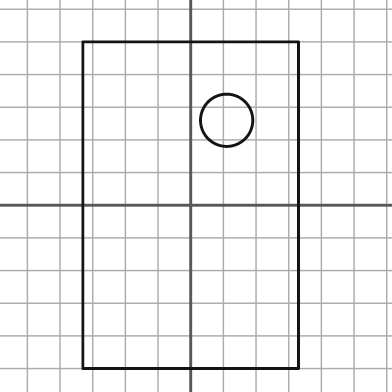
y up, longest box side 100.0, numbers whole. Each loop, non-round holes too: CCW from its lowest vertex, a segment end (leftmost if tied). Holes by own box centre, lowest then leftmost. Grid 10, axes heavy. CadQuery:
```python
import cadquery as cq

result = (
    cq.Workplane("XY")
    .moveTo(-33.0, -50.0)
    .lineTo(33.0, -50.0)
    .lineTo(33.0, 50.0)
    .lineTo(-33.0, 50.0)
    .close()
    .moveTo(11.0, 26.0)
    .circle(8.0)
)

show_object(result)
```